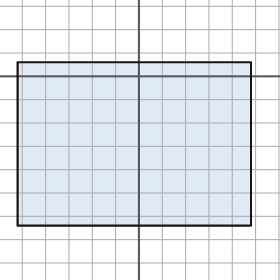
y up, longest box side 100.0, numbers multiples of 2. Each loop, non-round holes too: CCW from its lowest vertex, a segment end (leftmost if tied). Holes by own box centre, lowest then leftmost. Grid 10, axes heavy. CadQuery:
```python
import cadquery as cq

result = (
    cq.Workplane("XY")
    .moveTo(-52.0, -64.0)
    .lineTo(48.0, -64.0)
    .lineTo(48.0, 6.0)
    .lineTo(-52.0, 6.0)
    .close()
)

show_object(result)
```